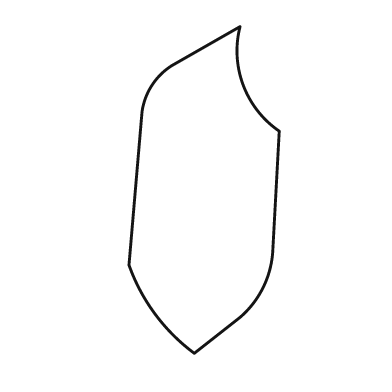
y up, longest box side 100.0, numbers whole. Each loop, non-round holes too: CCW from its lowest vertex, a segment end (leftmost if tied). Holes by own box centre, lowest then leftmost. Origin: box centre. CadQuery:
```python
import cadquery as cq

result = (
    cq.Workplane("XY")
    .moveTo(-3.0, -50.0)
    .lineTo(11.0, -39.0)
    .threePointArc((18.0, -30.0), (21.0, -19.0))
    .lineTo(23.0, 18.0)
    .threePointArc((12.0, 32.0), (11.0, 50.0))
    .lineTo(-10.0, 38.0)
    .threePointArc((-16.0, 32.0), (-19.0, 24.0))
    .lineTo(-23.0, -23.0)
    .threePointArc((-15.0, -38.0), (-3.0, -50.0))
    .close()
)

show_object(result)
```